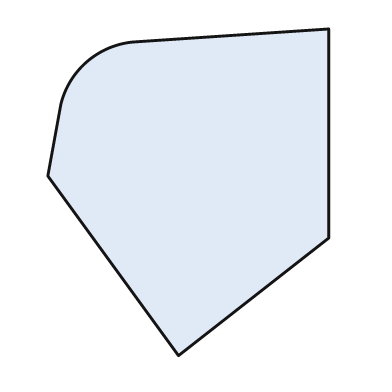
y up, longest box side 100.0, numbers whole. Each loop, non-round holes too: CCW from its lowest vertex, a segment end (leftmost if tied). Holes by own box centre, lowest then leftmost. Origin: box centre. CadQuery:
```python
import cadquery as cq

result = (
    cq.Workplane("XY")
    .moveTo(-3.0, -50.0)
    .lineTo(43.0, -14.0)
    .lineTo(43.0, 50.0)
    .lineTo(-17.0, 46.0)
    .threePointArc((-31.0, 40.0), (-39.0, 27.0))
    .lineTo(-43.0, 5.0)
    .close()
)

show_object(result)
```